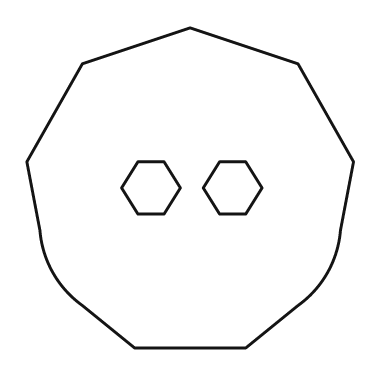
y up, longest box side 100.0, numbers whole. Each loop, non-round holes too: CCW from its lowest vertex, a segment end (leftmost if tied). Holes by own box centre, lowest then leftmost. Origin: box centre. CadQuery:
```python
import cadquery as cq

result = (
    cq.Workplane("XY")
    .moveTo(-17.0, -49.0)
    .lineTo(17.0, -49.0)
    .lineTo(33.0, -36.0)
    .threePointArc((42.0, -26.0), (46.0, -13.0))
    .lineTo(50.0, 8.0)
    .lineTo(33.0, 38.0)
    .lineTo(0.0, 49.0)
    .lineTo(-33.0, 38.0)
    .lineTo(-50.0, 8.0)
    .lineTo(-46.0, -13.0)
    .threePointArc((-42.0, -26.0), (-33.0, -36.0))
    .close()
    .moveTo(-16.0, -8.0)
    .lineTo(-8.0, -8.0)
    .lineTo(-3.0, 0.0)
    .lineTo(-8.0, 8.0)
    .lineTo(-16.0, 8.0)
    .lineTo(-21.0, 0.0)
    .close()
    .moveTo(9.0, -8.0)
    .lineTo(17.0, -8.0)
    .lineTo(22.0, 0.0)
    .lineTo(17.0, 8.0)
    .lineTo(9.0, 8.0)
    .lineTo(4.0, 0.0)
    .close()
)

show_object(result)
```